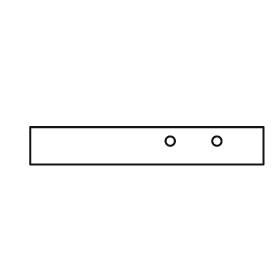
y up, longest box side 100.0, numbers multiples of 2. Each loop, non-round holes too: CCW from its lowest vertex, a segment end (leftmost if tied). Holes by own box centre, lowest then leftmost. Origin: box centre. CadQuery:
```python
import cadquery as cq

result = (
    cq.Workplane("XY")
    .moveTo(-50.0, -8.0)
    .lineTo(50.0, -8.0)
    .lineTo(50.0, 8.0)
    .lineTo(-50.0, 8.0)
    .close()
    .moveTo(10.0, 2.0)
    .circle(2.0)
    .moveTo(30.0, 2.0)
    .circle(2.0)
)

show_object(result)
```